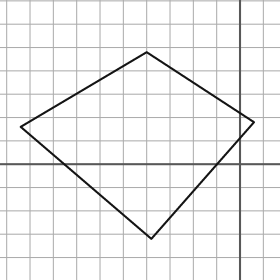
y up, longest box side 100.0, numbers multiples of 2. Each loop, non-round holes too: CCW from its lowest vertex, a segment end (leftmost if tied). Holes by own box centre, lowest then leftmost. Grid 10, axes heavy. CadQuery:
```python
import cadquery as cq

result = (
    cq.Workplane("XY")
    .moveTo(-38.0, -32.0)
    .lineTo(6.0, 18.0)
    .lineTo(-40.0, 48.0)
    .lineTo(-94.0, 16.0)
    .close()
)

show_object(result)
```